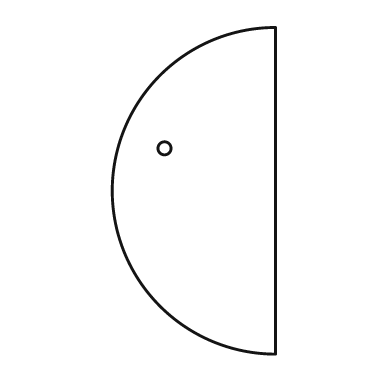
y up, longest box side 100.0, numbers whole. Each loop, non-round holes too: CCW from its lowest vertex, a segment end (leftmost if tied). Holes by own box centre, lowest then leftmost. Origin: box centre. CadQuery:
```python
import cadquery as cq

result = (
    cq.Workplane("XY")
    .moveTo(25.0, -50.0)
    .lineTo(25.0, 50.0)
    .threePointArc((-25.0, 0.0), (25.0, -50.0))
    .close()
    .moveTo(-9.0, 13.0)
    .circle(2.0)
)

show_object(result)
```